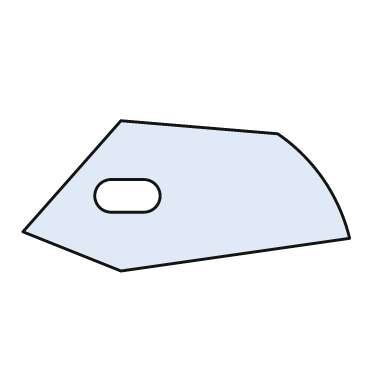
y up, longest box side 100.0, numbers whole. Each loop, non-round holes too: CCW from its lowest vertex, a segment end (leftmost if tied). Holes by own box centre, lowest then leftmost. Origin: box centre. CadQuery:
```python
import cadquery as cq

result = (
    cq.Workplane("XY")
    .moveTo(-20.0, -23.0)
    .lineTo(50.0, -13.0)
    .threePointArc((42.0, 5.0), (28.0, 19.0))
    .lineTo(-20.0, 23.0)
    .lineTo(-50.0, -11.0)
    .close()
    .moveTo(-23.0, -5.0)
    .lineTo(-13.0, -5.0)
    .threePointArc((-8.0, 0.0), (-13.0, 5.0))
    .lineTo(-23.0, 5.0)
    .threePointArc((-28.0, 0.0), (-23.0, -5.0))
    .close()
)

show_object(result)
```